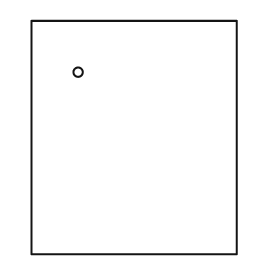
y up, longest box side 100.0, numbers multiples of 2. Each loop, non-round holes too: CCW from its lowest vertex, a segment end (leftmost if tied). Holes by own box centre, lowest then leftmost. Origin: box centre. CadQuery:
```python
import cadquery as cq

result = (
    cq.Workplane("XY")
    .moveTo(-44.0, -50.0)
    .lineTo(44.0, -50.0)
    .lineTo(44.0, 50.0)
    .lineTo(-44.0, 50.0)
    .close()
    .moveTo(-24.0, 28.0)
    .circle(2.0)
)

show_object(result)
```